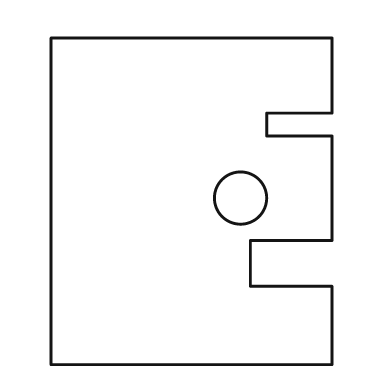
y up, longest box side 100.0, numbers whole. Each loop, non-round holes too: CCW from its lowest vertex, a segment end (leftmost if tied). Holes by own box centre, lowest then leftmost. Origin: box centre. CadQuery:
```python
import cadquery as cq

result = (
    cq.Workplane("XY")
    .moveTo(-43.0, -50.0)
    .lineTo(43.0, -50.0)
    .lineTo(43.0, -26.0)
    .lineTo(18.0, -26.0)
    .lineTo(18.0, -12.0)
    .lineTo(43.0, -12.0)
    .lineTo(43.0, 20.0)
    .lineTo(23.0, 20.0)
    .lineTo(23.0, 27.0)
    .lineTo(43.0, 27.0)
    .lineTo(43.0, 50.0)
    .lineTo(-43.0, 50.0)
    .close()
    .moveTo(15.0, 1.0)
    .circle(8.0)
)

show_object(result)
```